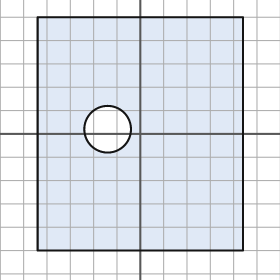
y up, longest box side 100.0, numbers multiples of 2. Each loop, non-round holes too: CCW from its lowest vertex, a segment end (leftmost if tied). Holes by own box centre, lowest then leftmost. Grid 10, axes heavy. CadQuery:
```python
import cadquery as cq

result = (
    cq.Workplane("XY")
    .moveTo(-44.0, -50.0)
    .lineTo(44.0, -50.0)
    .lineTo(44.0, 50.0)
    .lineTo(-44.0, 50.0)
    .close()
    .moveTo(-14.0, 2.0)
    .circle(10.0)
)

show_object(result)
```